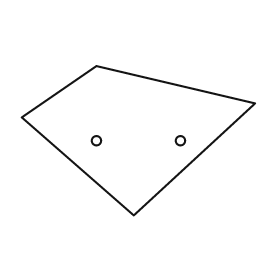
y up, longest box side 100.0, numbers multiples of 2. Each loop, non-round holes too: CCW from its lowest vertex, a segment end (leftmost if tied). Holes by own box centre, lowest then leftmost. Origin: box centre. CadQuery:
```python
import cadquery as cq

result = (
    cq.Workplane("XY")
    .moveTo(-2.0, -32.0)
    .lineTo(50.0, 16.0)
    .lineTo(-18.0, 32.0)
    .lineTo(-50.0, 10.0)
    .close()
    .moveTo(-18.0, 0.0)
    .circle(2.0)
    .moveTo(18.0, 0.0)
    .circle(2.0)
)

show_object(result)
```